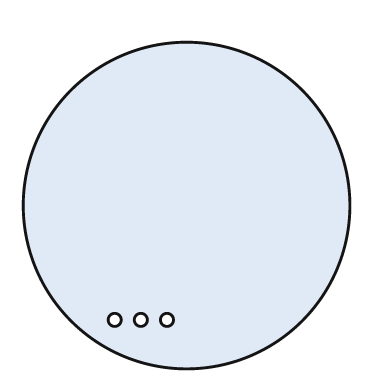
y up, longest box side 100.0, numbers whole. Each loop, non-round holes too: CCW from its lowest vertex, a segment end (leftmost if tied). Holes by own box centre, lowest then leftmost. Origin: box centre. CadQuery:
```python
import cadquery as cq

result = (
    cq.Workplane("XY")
    .moveTo(0.0, 0.0)
    .circle(50.0)
    .moveTo(-22.0, -35.0)
    .circle(2.0)
    .moveTo(-14.0, -35.0)
    .circle(2.0)
    .moveTo(-6.0, -35.0)
    .circle(2.0)
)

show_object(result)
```